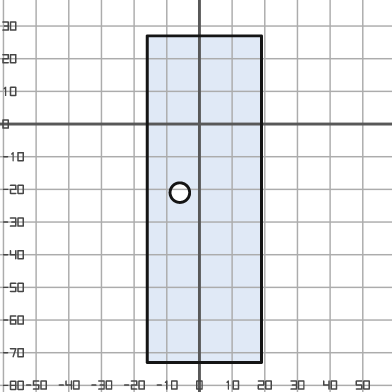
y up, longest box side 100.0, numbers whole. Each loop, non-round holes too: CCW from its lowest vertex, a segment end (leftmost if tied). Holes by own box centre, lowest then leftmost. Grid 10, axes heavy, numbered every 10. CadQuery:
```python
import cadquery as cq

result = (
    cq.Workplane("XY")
    .moveTo(-16.0, -73.0)
    .lineTo(19.0, -73.0)
    .lineTo(19.0, 27.0)
    .lineTo(-16.0, 27.0)
    .close()
    .moveTo(-6.0, -21.0)
    .circle(3.0)
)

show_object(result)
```